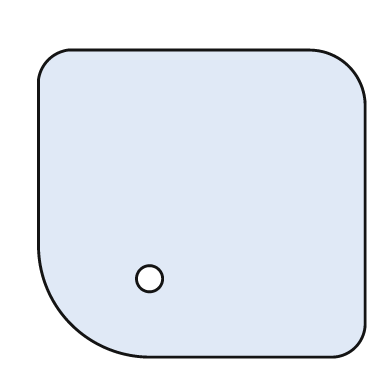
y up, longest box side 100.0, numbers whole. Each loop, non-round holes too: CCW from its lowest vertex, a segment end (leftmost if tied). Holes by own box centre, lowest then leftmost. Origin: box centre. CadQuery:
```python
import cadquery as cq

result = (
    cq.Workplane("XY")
    .moveTo(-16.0, -47.0)
    .lineTo(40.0, -47.0)
    .threePointArc((47.0, -44.0), (50.0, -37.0))
    .lineTo(50.0, 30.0)
    .threePointArc((45.0, 42.0), (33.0, 47.0))
    .lineTo(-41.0, 47.0)
    .threePointArc((-47.0, 44.0), (-50.0, 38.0))
    .lineTo(-50.0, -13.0)
    .threePointArc((-40.0, -37.0), (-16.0, -47.0))
    .close()
    .moveTo(-16.0, -23.0)
    .circle(4.0)
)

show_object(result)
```